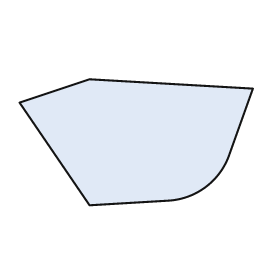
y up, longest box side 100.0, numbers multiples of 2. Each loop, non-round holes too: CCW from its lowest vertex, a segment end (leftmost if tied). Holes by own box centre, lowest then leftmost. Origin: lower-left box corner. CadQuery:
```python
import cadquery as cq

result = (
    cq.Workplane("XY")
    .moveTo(30.0, 0.0)
    .lineTo(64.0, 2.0)
    .threePointArc((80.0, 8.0), (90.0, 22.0))
    .lineTo(100.0, 50.0)
    .lineTo(30.0, 54.0)
    .lineTo(0.0, 44.0)
    .close()
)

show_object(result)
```